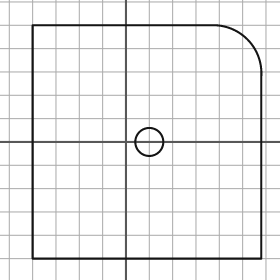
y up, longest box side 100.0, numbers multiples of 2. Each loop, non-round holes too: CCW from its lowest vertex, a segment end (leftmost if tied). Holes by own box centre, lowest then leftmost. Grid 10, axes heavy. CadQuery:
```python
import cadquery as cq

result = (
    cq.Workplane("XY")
    .moveTo(-40.0, -50.0)
    .lineTo(58.0, -50.0)
    .lineTo(58.0, 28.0)
    .threePointArc((52.0, 44.0), (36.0, 50.0))
    .lineTo(-40.0, 50.0)
    .close()
    .moveTo(10.0, 0.0)
    .circle(6.0)
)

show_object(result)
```